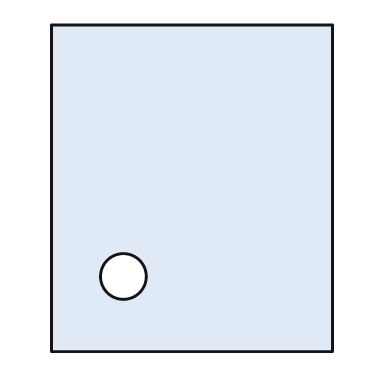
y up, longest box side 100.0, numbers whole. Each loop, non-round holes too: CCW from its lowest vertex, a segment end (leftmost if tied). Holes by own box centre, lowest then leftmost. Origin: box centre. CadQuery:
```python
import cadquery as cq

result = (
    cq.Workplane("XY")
    .moveTo(-43.0, -50.0)
    .lineTo(43.0, -50.0)
    .lineTo(43.0, 50.0)
    .lineTo(-43.0, 50.0)
    .close()
    .moveTo(-21.0, -27.0)
    .circle(7.0)
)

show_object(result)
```